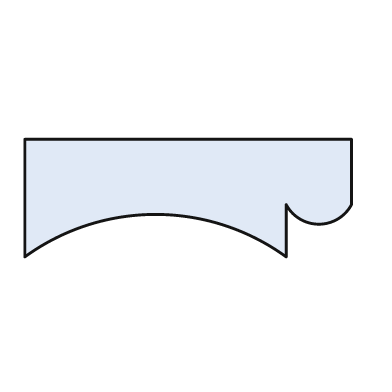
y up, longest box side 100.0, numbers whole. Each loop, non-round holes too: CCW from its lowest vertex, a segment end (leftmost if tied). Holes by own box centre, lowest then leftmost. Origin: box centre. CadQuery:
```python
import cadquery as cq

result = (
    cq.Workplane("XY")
    .moveTo(-50.0, -18.0)
    .threePointArc((-10.0, -5.0), (30.0, -18.0))
    .lineTo(30.0, -2.0)
    .threePointArc((40.0, -8.0), (50.0, -2.0))
    .lineTo(50.0, 18.0)
    .lineTo(-50.0, 18.0)
    .close()
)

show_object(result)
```